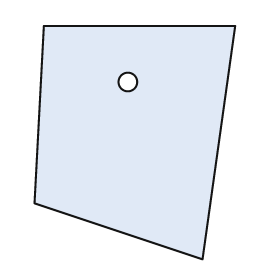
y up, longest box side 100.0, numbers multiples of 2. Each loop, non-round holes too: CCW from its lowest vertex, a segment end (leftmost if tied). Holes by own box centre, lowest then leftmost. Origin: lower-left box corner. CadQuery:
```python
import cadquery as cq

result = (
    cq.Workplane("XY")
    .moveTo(72.0, 0.0)
    .lineTo(86.0, 100.0)
    .lineTo(4.0, 100.0)
    .lineTo(0.0, 24.0)
    .close()
    .moveTo(40.0, 76.0)
    .circle(4.0)
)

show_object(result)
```